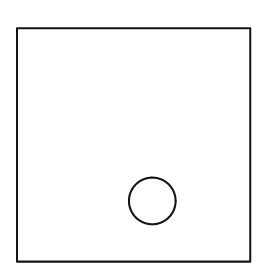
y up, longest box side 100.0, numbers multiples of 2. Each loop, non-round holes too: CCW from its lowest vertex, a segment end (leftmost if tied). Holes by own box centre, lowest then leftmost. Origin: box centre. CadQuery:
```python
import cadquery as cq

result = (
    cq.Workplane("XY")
    .moveTo(-50.0, -50.0)
    .lineTo(50.0, -50.0)
    .lineTo(50.0, 50.0)
    .lineTo(-50.0, 50.0)
    .close()
    .moveTo(8.0, -24.0)
    .circle(10.0)
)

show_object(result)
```